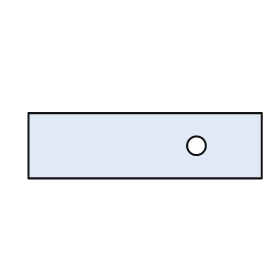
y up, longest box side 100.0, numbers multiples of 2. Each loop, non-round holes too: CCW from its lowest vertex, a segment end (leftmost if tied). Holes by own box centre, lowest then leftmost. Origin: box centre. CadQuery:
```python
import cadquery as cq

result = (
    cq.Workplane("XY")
    .moveTo(-50.0, -14.0)
    .lineTo(50.0, -14.0)
    .lineTo(50.0, 14.0)
    .lineTo(-50.0, 14.0)
    .close()
    .moveTo(22.0, 0.0)
    .circle(4.0)
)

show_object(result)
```